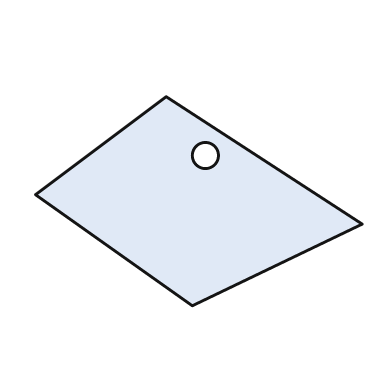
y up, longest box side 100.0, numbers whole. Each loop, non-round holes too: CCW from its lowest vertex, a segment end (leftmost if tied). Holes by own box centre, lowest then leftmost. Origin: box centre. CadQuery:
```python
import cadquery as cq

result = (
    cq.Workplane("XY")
    .moveTo(-2.0, -32.0)
    .lineTo(50.0, -7.0)
    .lineTo(-10.0, 32.0)
    .lineTo(-50.0, 2.0)
    .close()
    .moveTo(2.0, 14.0)
    .circle(4.0)
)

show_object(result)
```